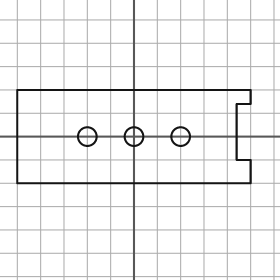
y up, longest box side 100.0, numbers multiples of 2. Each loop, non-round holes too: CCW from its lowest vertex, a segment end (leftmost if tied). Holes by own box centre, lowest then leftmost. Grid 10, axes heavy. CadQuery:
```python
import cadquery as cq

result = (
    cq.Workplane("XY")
    .moveTo(-50.0, -20.0)
    .lineTo(50.0, -20.0)
    .lineTo(50.0, -10.0)
    .lineTo(44.0, -10.0)
    .lineTo(44.0, 14.0)
    .lineTo(50.0, 14.0)
    .lineTo(50.0, 20.0)
    .lineTo(-50.0, 20.0)
    .close()
    .moveTo(-20.0, 0.0)
    .circle(4.0)
    .moveTo(0.0, 0.0)
    .circle(4.0)
    .moveTo(20.0, 0.0)
    .circle(4.0)
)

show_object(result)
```